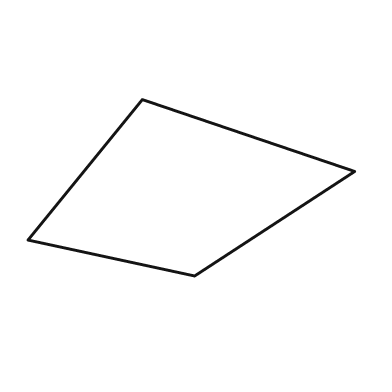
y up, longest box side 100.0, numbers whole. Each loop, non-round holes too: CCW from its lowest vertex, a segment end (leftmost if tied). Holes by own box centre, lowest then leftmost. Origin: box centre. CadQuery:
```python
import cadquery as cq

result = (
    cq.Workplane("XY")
    .moveTo(1.0, -27.0)
    .lineTo(50.0, 5.0)
    .lineTo(-15.0, 27.0)
    .lineTo(-50.0, -16.0)
    .close()
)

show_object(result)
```